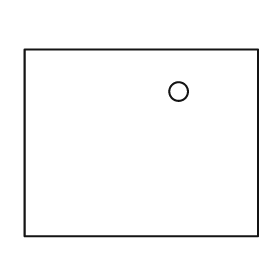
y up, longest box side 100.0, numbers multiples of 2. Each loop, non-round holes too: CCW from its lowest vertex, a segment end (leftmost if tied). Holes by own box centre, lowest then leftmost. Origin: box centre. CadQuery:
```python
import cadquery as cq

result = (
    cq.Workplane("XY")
    .moveTo(-50.0, -40.0)
    .lineTo(50.0, -40.0)
    .lineTo(50.0, 40.0)
    .lineTo(-50.0, 40.0)
    .close()
    .moveTo(16.0, 22.0)
    .circle(4.0)
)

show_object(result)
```